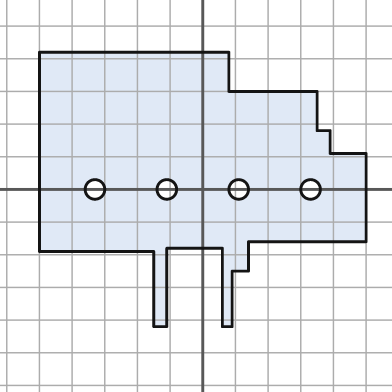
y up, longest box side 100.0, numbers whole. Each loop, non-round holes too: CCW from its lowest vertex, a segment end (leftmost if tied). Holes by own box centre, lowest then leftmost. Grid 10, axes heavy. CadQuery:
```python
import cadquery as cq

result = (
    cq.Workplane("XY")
    .moveTo(-15.0, -42.0)
    .lineTo(-11.0, -42.0)
    .lineTo(-11.0, -18.0)
    .lineTo(6.0, -18.0)
    .lineTo(6.0, -42.0)
    .lineTo(9.0, -42.0)
    .lineTo(9.0, -25.0)
    .lineTo(14.0, -25.0)
    .lineTo(14.0, -16.0)
    .lineTo(50.0, -16.0)
    .lineTo(50.0, 11.0)
    .lineTo(39.0, 11.0)
    .lineTo(39.0, 18.0)
    .lineTo(35.0, 18.0)
    .lineTo(35.0, 30.0)
    .lineTo(8.0, 30.0)
    .lineTo(8.0, 42.0)
    .lineTo(-50.0, 42.0)
    .lineTo(-50.0, -19.0)
    .lineTo(-15.0, -19.0)
    .close()
    .moveTo(-33.0, 0.0)
    .circle(3.0)
    .moveTo(-11.0, 0.0)
    .circle(3.0)
    .moveTo(11.0, 0.0)
    .circle(3.0)
    .moveTo(33.0, 0.0)
    .circle(3.0)
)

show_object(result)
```